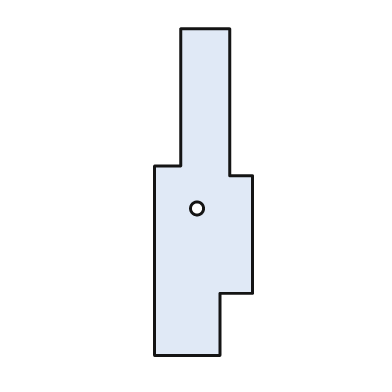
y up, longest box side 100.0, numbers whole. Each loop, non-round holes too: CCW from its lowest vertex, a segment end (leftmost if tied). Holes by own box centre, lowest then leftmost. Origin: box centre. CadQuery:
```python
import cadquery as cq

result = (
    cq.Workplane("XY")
    .moveTo(-15.0, -50.0)
    .lineTo(5.0, -50.0)
    .lineTo(5.0, -31.0)
    .lineTo(15.0, -31.0)
    .lineTo(15.0, 5.0)
    .lineTo(8.0, 5.0)
    .lineTo(8.0, 50.0)
    .lineTo(-7.0, 50.0)
    .lineTo(-7.0, 8.0)
    .lineTo(-15.0, 8.0)
    .close()
    .moveTo(-2.0, -5.0)
    .circle(2.0)
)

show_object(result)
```